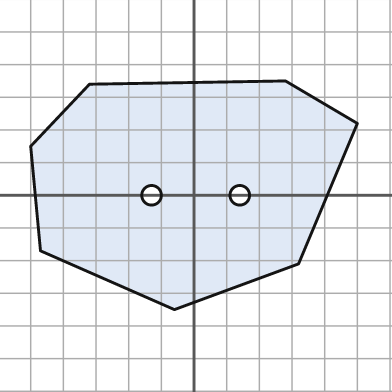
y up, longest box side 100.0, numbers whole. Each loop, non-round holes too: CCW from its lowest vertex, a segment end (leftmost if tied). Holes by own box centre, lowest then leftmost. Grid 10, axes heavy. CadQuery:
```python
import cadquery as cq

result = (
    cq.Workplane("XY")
    .moveTo(-6.0, -35.0)
    .lineTo(32.0, -21.0)
    .lineTo(50.0, 22.0)
    .lineTo(28.0, 35.0)
    .lineTo(-32.0, 34.0)
    .lineTo(-50.0, 15.0)
    .lineTo(-47.0, -17.0)
    .close()
    .moveTo(-13.0, 0.0)
    .circle(3.0)
    .moveTo(14.0, 0.0)
    .circle(3.0)
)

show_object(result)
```